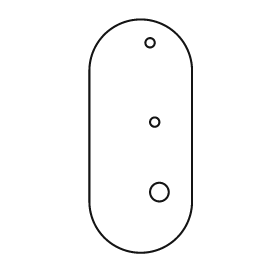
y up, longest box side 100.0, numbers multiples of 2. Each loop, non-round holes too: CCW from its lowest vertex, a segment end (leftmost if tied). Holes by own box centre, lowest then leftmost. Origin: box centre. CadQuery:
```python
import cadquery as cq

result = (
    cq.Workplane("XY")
    .moveTo(-22.0, -28.0)
    .threePointArc((0.0, -50.0), (22.0, -28.0))
    .lineTo(22.0, 28.0)
    .threePointArc((0.0, 50.0), (-22.0, 28.0))
    .close()
    .moveTo(8.0, -24.0)
    .circle(4.0)
    .moveTo(6.0, 6.0)
    .circle(2.0)
    .moveTo(4.0, 40.0)
    .circle(2.0)
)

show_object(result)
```